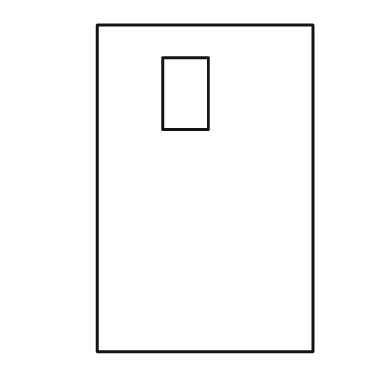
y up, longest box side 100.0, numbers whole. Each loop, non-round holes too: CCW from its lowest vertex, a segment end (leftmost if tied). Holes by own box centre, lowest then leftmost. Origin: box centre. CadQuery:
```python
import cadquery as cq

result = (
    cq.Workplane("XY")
    .moveTo(-33.0, -50.0)
    .lineTo(33.0, -50.0)
    .lineTo(33.0, 50.0)
    .lineTo(-33.0, 50.0)
    .close()
    .moveTo(-13.0, 18.0)
    .lineTo(1.0, 18.0)
    .lineTo(1.0, 40.0)
    .lineTo(-13.0, 40.0)
    .close()
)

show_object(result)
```